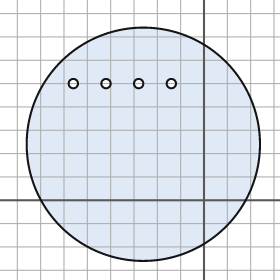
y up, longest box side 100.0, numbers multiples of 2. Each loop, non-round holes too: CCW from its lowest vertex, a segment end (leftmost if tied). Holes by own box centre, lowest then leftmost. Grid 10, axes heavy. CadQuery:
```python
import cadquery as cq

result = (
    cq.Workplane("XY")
    .moveTo(-26.0, 24.0)
    .circle(50.0)
    .moveTo(-56.0, 50.0)
    .circle(2.0)
    .moveTo(-42.0, 50.0)
    .circle(2.0)
    .moveTo(-28.0, 50.0)
    .circle(2.0)
    .moveTo(-14.0, 50.0)
    .circle(2.0)
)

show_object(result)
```